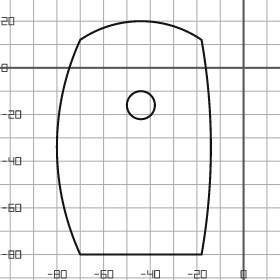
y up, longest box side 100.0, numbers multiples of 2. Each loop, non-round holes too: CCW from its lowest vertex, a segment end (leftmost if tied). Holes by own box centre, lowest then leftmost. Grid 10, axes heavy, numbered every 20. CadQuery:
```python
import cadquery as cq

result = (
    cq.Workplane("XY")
    .moveTo(-70.0, -80.0)
    .lineTo(-18.0, -80.0)
    .threePointArc((-14.0, -34.0), (-18.0, 12.0))
    .threePointArc((-44.0, 20.0), (-70.0, 12.0))
    .threePointArc((-80.0, -34.0), (-70.0, -80.0))
    .close()
    .moveTo(-44.0, -16.0)
    .circle(6.0)
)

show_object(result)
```